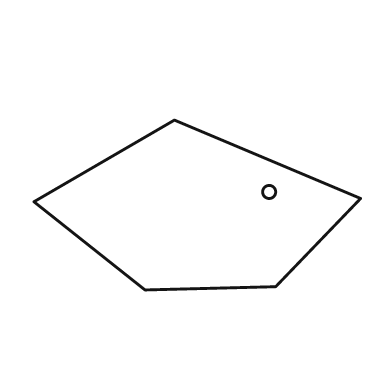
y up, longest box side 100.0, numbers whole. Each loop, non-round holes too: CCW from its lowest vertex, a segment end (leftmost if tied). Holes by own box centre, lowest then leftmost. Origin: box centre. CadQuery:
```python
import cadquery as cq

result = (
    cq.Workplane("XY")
    .moveTo(-16.0, -26.0)
    .lineTo(24.0, -25.0)
    .lineTo(50.0, 2.0)
    .lineTo(-7.0, 26.0)
    .lineTo(-50.0, 1.0)
    .close()
    .moveTo(22.0, 4.0)
    .circle(2.0)
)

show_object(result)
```